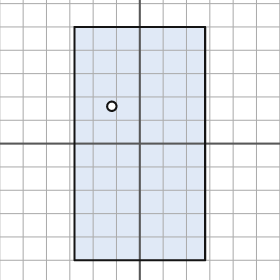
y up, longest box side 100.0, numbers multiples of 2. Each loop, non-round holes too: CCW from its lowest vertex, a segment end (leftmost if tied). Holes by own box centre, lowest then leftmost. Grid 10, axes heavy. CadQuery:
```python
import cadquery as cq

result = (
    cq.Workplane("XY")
    .moveTo(-28.0, -50.0)
    .lineTo(28.0, -50.0)
    .lineTo(28.0, 50.0)
    .lineTo(-28.0, 50.0)
    .close()
    .moveTo(-12.0, 16.0)
    .circle(2.0)
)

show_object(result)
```